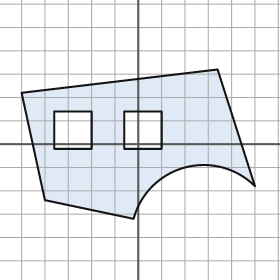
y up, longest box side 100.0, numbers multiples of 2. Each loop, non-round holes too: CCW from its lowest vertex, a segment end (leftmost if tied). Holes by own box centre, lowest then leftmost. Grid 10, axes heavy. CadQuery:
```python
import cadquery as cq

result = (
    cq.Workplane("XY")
    .moveTo(-2.0, -32.0)
    .threePointArc((20.0, -10.0), (50.0, -18.0))
    .lineTo(34.0, 32.0)
    .lineTo(-50.0, 22.0)
    .lineTo(-40.0, -24.0)
    .close()
    .moveTo(-36.0, -2.0)
    .lineTo(-20.0, -2.0)
    .lineTo(-20.0, 14.0)
    .lineTo(-36.0, 14.0)
    .close()
    .moveTo(-6.0, -2.0)
    .lineTo(10.0, -2.0)
    .lineTo(10.0, 14.0)
    .lineTo(-6.0, 14.0)
    .close()
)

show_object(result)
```